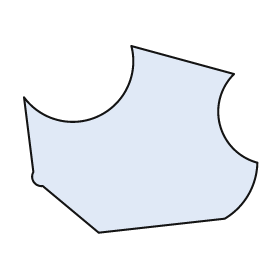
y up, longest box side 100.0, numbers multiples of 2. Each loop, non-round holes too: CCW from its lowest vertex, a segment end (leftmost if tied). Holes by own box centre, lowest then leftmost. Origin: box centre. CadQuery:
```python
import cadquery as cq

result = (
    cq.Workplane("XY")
    .moveTo(-18.0, -40.0)
    .lineTo(36.0, -34.0)
    .threePointArc((46.0, -24.0), (50.0, -10.0))
    .threePointArc((34.0, 6.0), (40.0, 28.0))
    .lineTo(-4.0, 40.0)
    .threePointArc((-18.0, 10.0), (-50.0, 18.0))
    .lineTo(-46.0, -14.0)
    .threePointArc((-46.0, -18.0), (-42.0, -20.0))
    .close()
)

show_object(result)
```